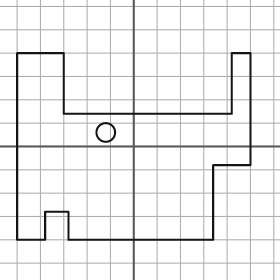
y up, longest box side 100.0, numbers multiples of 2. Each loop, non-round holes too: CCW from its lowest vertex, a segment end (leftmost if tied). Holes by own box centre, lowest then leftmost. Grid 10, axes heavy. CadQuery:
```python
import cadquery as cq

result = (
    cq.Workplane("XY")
    .moveTo(-50.0, -40.0)
    .lineTo(-38.0, -40.0)
    .lineTo(-38.0, -28.0)
    .lineTo(-28.0, -28.0)
    .lineTo(-28.0, -40.0)
    .lineTo(34.0, -40.0)
    .lineTo(34.0, -8.0)
    .lineTo(50.0, -8.0)
    .lineTo(50.0, 40.0)
    .lineTo(42.0, 40.0)
    .lineTo(42.0, 14.0)
    .lineTo(-30.0, 14.0)
    .lineTo(-30.0, 40.0)
    .lineTo(-50.0, 40.0)
    .close()
    .moveTo(-12.0, 6.0)
    .circle(4.0)
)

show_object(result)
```